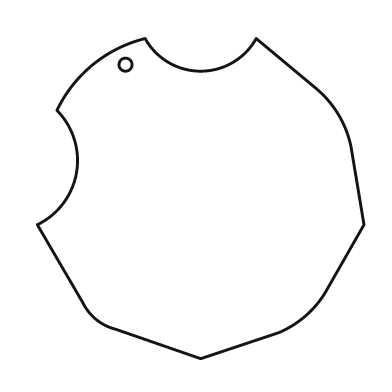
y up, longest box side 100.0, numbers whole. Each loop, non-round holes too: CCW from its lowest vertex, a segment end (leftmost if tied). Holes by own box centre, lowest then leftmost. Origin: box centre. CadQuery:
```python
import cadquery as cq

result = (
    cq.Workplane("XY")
    .moveTo(0.0, -49.0)
    .lineTo(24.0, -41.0)
    .threePointArc((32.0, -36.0), (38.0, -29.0))
    .lineTo(50.0, -8.0)
    .lineTo(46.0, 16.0)
    .threePointArc((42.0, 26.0), (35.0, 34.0))
    .lineTo(17.0, 49.0)
    .threePointArc((0.0, 39.0), (-17.0, 49.0))
    .threePointArc((-33.0, 41.0), (-44.0, 27.0))
    .threePointArc((-38.0, 8.0), (-50.0, -8.0))
    .lineTo(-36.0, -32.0)
    .threePointArc((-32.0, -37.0), (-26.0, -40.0))
    .close()
    .moveTo(-23.0, 41.0)
    .circle(2.0)
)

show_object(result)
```